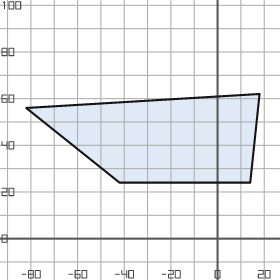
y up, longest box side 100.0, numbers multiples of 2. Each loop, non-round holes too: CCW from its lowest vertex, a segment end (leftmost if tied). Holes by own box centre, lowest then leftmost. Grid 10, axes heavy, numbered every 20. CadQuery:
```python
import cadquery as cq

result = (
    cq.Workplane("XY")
    .moveTo(-42.0, 24.0)
    .lineTo(14.0, 24.0)
    .lineTo(18.0, 62.0)
    .lineTo(-82.0, 56.0)
    .close()
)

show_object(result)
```